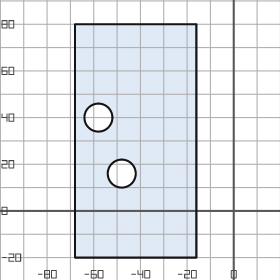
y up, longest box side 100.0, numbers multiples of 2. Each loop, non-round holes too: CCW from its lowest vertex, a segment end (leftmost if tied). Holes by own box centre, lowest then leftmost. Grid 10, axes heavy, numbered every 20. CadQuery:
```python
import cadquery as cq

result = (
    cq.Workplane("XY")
    .moveTo(-68.0, -20.0)
    .lineTo(-16.0, -20.0)
    .lineTo(-16.0, 80.0)
    .lineTo(-68.0, 80.0)
    .close()
    .moveTo(-48.0, 16.0)
    .circle(6.0)
    .moveTo(-58.0, 40.0)
    .circle(6.0)
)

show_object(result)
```